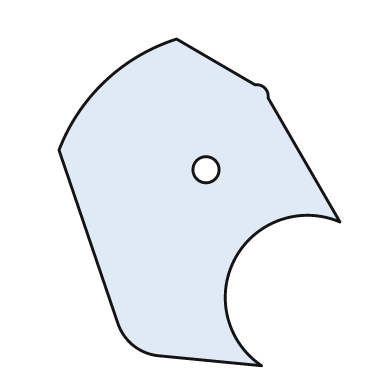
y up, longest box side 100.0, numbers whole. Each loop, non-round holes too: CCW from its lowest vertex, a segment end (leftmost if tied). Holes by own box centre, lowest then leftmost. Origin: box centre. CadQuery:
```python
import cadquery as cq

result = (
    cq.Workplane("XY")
    .moveTo(19.0, -50.0)
    .threePointArc((11.0, -17.0), (43.0, -6.0))
    .lineTo(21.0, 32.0)
    .threePointArc((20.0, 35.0), (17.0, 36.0))
    .lineTo(-7.0, 50.0)
    .threePointArc((-29.0, 37.0), (-43.0, 16.0))
    .lineTo(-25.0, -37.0)
    .threePointArc((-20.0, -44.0), (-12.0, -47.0))
    .close()
    .moveTo(2.0, 10.0)
    .circle(4.0)
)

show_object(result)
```